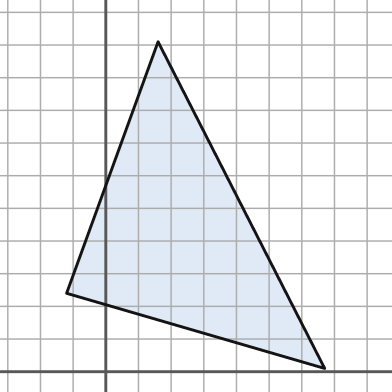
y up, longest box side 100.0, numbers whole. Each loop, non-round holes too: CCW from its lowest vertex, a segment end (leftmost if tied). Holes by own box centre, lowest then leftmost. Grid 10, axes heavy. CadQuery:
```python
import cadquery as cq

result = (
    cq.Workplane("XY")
    .moveTo(67.0, 1.0)
    .lineTo(16.0, 101.0)
    .lineTo(-12.0, 24.0)
    .close()
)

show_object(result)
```